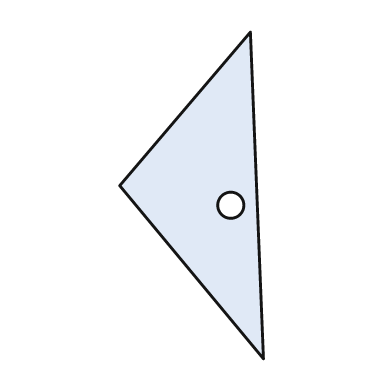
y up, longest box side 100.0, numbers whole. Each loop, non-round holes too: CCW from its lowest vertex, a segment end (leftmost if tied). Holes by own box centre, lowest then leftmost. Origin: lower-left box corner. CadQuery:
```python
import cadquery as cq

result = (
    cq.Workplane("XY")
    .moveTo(44.0, 0.0)
    .lineTo(40.0, 100.0)
    .lineTo(0.0, 53.0)
    .close()
    .moveTo(34.0, 47.0)
    .circle(4.0)
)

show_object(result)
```